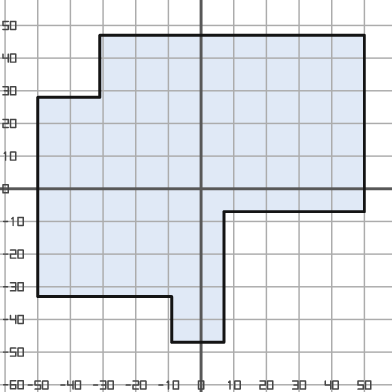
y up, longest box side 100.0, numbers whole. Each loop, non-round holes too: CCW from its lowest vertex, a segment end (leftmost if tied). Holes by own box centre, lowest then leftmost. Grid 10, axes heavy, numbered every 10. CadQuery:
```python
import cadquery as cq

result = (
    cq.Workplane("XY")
    .moveTo(-9.0, -47.0)
    .lineTo(7.0, -47.0)
    .lineTo(7.0, -7.0)
    .lineTo(50.0, -7.0)
    .lineTo(50.0, 47.0)
    .lineTo(-31.0, 47.0)
    .lineTo(-31.0, 28.0)
    .lineTo(-50.0, 28.0)
    .lineTo(-50.0, -33.0)
    .lineTo(-9.0, -33.0)
    .close()
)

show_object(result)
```